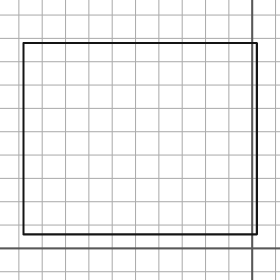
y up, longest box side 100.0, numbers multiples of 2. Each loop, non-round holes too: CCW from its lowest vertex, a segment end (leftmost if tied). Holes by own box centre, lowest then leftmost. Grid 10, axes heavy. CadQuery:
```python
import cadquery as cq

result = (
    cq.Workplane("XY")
    .moveTo(-98.0, 6.0)
    .lineTo(2.0, 6.0)
    .lineTo(2.0, 88.0)
    .lineTo(-98.0, 88.0)
    .close()
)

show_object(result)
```